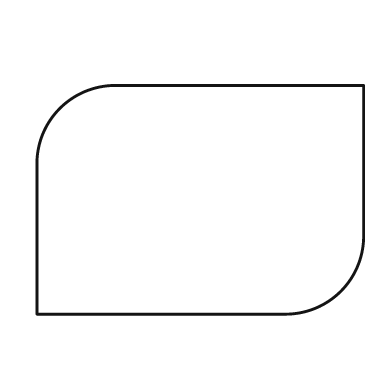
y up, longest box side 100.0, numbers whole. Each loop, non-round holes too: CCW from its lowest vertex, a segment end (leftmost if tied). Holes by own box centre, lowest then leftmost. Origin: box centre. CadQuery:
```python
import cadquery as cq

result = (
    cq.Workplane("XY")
    .moveTo(-50.0, -35.0)
    .lineTo(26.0, -35.0)
    .threePointArc((43.0, -28.0), (50.0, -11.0))
    .lineTo(50.0, 35.0)
    .lineTo(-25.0, 35.0)
    .threePointArc((-43.0, 28.0), (-50.0, 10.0))
    .close()
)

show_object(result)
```